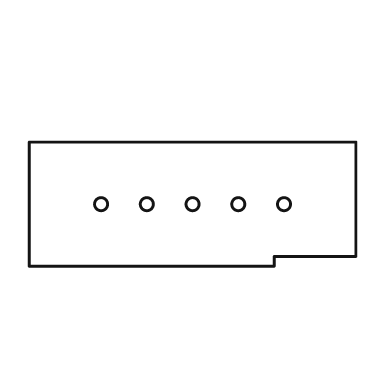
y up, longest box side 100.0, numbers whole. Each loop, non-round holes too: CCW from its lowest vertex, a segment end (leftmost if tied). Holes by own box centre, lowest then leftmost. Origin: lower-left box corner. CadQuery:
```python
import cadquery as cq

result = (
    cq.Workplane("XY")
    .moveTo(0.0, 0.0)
    .lineTo(75.0, 0.0)
    .lineTo(75.0, 3.0)
    .lineTo(100.0, 3.0)
    .lineTo(100.0, 38.0)
    .lineTo(0.0, 38.0)
    .close()
    .moveTo(22.0, 19.0)
    .circle(2.0)
    .moveTo(36.0, 19.0)
    .circle(2.0)
    .moveTo(50.0, 19.0)
    .circle(2.0)
    .moveTo(64.0, 19.0)
    .circle(2.0)
    .moveTo(78.0, 19.0)
    .circle(2.0)
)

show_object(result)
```